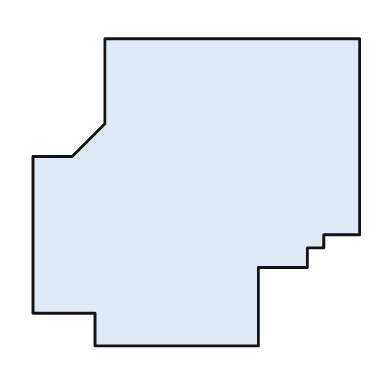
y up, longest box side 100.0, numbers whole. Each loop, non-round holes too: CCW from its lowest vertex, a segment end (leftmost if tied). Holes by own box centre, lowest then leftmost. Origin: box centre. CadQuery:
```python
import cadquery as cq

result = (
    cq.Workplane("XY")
    .moveTo(-31.0, -47.0)
    .lineTo(19.0, -47.0)
    .lineTo(19.0, -23.0)
    .lineTo(34.0, -23.0)
    .lineTo(34.0, -17.0)
    .lineTo(39.0, -17.0)
    .lineTo(39.0, -13.0)
    .lineTo(50.0, -13.0)
    .lineTo(50.0, 47.0)
    .lineTo(-28.0, 47.0)
    .lineTo(-28.0, 21.0)
    .lineTo(-38.0, 11.0)
    .lineTo(-50.0, 11.0)
    .lineTo(-50.0, -37.0)
    .lineTo(-31.0, -37.0)
    .close()
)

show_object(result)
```